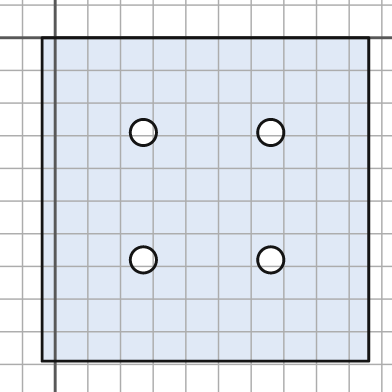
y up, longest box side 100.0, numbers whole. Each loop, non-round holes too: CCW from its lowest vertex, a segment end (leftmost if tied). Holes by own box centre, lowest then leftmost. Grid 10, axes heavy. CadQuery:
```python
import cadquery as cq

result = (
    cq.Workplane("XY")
    .moveTo(-4.0, -99.0)
    .lineTo(96.0, -99.0)
    .lineTo(96.0, 0.0)
    .lineTo(-4.0, 0.0)
    .close()
    .moveTo(27.0, -68.0)
    .circle(4.0)
    .moveTo(66.0, -68.0)
    .circle(4.0)
    .moveTo(27.0, -29.0)
    .circle(4.0)
    .moveTo(66.0, -29.0)
    .circle(4.0)
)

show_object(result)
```